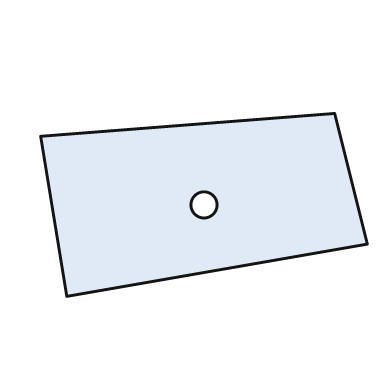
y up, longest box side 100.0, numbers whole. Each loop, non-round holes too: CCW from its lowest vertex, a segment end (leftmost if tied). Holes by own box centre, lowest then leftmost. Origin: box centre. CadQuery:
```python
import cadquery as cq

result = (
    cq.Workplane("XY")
    .moveTo(-42.0, -28.0)
    .lineTo(50.0, -12.0)
    .lineTo(40.0, 28.0)
    .lineTo(-50.0, 21.0)
    .close()
    .moveTo(0.0, 0.0)
    .circle(4.0)
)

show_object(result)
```